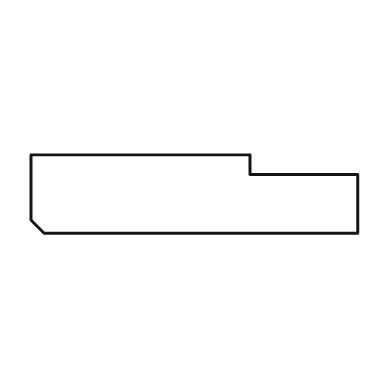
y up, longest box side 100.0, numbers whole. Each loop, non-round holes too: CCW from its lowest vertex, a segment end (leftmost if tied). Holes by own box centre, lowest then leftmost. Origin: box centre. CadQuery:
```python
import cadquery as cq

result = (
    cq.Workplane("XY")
    .moveTo(-46.0, -12.0)
    .lineTo(50.0, -12.0)
    .lineTo(50.0, 6.0)
    .lineTo(17.0, 6.0)
    .lineTo(17.0, 12.0)
    .lineTo(-50.0, 12.0)
    .lineTo(-50.0, -8.0)
    .close()
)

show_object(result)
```